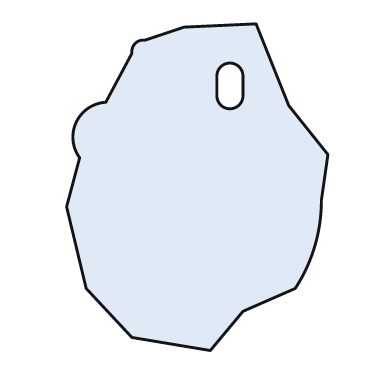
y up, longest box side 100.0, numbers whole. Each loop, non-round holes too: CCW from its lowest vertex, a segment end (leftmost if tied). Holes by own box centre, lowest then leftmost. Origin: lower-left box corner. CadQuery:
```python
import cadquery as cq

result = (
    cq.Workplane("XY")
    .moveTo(44.0, 0.0)
    .lineTo(54.0, 12.0)
    .lineTo(70.0, 19.0)
    .threePointArc((76.0, 32.0), (78.0, 46.0))
    .lineTo(80.0, 60.0)
    .lineTo(68.0, 75.0)
    .lineTo(58.0, 100.0)
    .lineTo(36.0, 99.0)
    .lineTo(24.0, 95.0)
    .threePointArc((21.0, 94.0), (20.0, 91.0))
    .lineTo(12.0, 76.0)
    .threePointArc((3.0, 70.0), (4.0, 59.0))
    .lineTo(0.0, 44.0)
    .lineTo(6.0, 19.0)
    .lineTo(20.0, 4.0)
    .close()
    .moveTo(46.0, 78.0)
    .threePointArc((50.0, 74.0), (54.0, 78.0))
    .lineTo(54.0, 84.0)
    .threePointArc((50.0, 88.0), (46.0, 84.0))
    .close()
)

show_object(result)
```